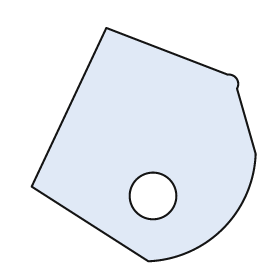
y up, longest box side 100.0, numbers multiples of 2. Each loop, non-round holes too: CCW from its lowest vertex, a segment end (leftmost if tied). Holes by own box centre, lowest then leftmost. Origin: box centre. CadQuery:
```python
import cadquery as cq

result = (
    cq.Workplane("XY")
    .moveTo(2.0, -50.0)
    .threePointArc((34.0, -36.0), (48.0, -4.0))
    .lineTo(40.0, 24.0)
    .threePointArc((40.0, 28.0), (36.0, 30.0))
    .lineTo(-16.0, 50.0)
    .lineTo(-48.0, -18.0)
    .close()
    .moveTo(4.0, -22.0)
    .circle(10.0)
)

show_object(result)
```